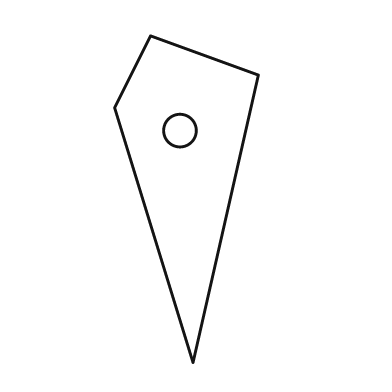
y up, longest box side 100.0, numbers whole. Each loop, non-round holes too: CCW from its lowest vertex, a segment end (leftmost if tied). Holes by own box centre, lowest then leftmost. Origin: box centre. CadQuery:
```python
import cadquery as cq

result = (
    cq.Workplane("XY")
    .moveTo(2.0, -50.0)
    .lineTo(22.0, 38.0)
    .lineTo(-11.0, 50.0)
    .lineTo(-22.0, 28.0)
    .close()
    .moveTo(-2.0, 21.0)
    .circle(5.0)
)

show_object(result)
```